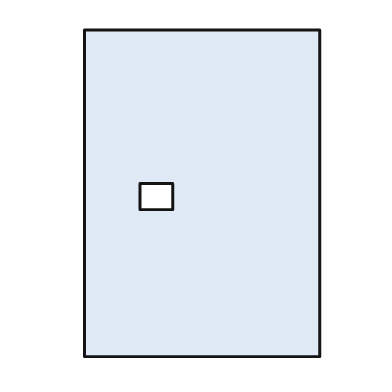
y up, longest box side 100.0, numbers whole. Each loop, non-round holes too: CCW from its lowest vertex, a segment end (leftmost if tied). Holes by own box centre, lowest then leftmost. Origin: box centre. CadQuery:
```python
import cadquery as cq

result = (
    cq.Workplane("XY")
    .moveTo(-36.0, -50.0)
    .lineTo(36.0, -50.0)
    .lineTo(36.0, 50.0)
    .lineTo(-36.0, 50.0)
    .close()
    .moveTo(-19.0, -5.0)
    .lineTo(-9.0, -5.0)
    .lineTo(-9.0, 3.0)
    .lineTo(-19.0, 3.0)
    .close()
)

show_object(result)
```